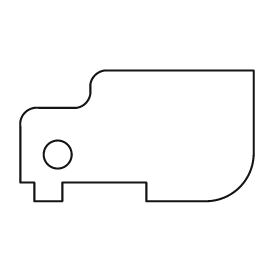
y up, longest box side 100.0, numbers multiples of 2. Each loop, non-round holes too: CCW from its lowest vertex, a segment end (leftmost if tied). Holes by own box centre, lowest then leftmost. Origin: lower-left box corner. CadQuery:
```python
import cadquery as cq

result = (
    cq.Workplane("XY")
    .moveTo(6.0, 0.0)
    .lineTo(18.0, 0.0)
    .lineTo(18.0, 8.0)
    .lineTo(54.0, 8.0)
    .lineTo(54.0, 0.0)
    .lineTo(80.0, 0.0)
    .threePointArc((94.0, 6.0), (100.0, 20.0))
    .lineTo(100.0, 56.0)
    .lineTo(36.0, 56.0)
    .threePointArc((32.0, 54.0), (30.0, 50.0))
    .lineTo(30.0, 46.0)
    .threePointArc((28.0, 42.0), (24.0, 40.0))
    .lineTo(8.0, 40.0)
    .threePointArc((2.0, 38.0), (0.0, 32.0))
    .lineTo(0.0, 8.0)
    .lineTo(6.0, 8.0)
    .close()
    .moveTo(16.0, 20.0)
    .circle(6.0)
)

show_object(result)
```